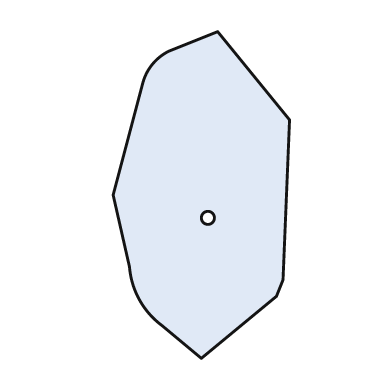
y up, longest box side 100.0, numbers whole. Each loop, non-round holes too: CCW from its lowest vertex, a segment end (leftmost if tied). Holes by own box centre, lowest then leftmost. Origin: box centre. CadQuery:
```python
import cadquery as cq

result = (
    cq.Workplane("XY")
    .moveTo(0.0, -50.0)
    .lineTo(23.0, -31.0)
    .lineTo(25.0, -26.0)
    .lineTo(27.0, 23.0)
    .lineTo(5.0, 50.0)
    .lineTo(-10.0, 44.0)
    .threePointArc((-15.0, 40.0), (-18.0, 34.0))
    .lineTo(-27.0, 0.0)
    .lineTo(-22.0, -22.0)
    .threePointArc((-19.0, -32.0), (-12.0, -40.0))
    .close()
    .moveTo(2.0, -7.0)
    .circle(2.0)
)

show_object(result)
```